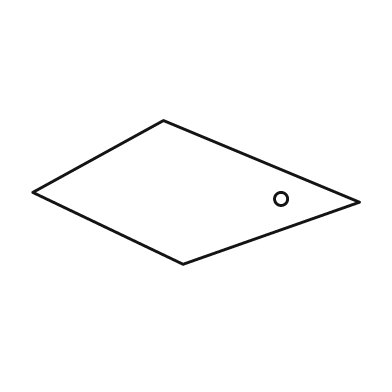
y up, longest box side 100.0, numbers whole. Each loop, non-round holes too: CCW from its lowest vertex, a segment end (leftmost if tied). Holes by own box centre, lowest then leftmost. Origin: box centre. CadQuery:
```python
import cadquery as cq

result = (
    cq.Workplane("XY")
    .moveTo(-4.0, -22.0)
    .lineTo(50.0, -3.0)
    .lineTo(-10.0, 22.0)
    .lineTo(-50.0, 0.0)
    .close()
    .moveTo(26.0, -2.0)
    .circle(2.0)
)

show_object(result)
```